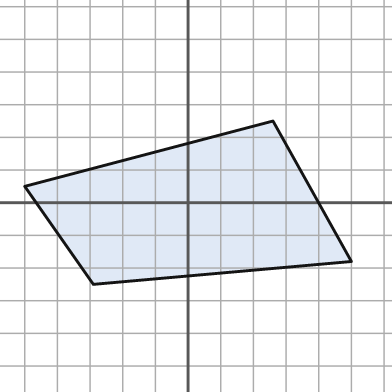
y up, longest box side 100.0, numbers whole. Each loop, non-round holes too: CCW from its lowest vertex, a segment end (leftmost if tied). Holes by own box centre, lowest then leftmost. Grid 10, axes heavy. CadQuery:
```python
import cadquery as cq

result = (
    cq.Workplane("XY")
    .moveTo(-29.0, -25.0)
    .lineTo(50.0, -18.0)
    .lineTo(26.0, 25.0)
    .lineTo(-50.0, 5.0)
    .close()
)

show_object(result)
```